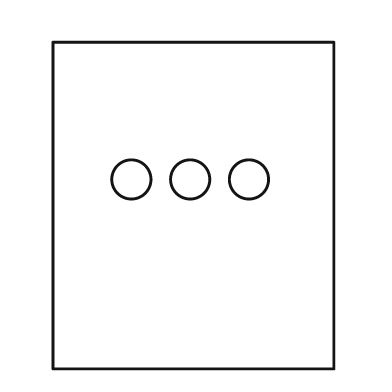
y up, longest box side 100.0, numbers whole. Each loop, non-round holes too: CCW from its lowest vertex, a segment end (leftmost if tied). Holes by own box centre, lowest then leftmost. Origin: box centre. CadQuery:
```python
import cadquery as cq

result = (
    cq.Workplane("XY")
    .moveTo(-43.0, -50.0)
    .lineTo(43.0, -50.0)
    .lineTo(43.0, 50.0)
    .lineTo(-43.0, 50.0)
    .close()
    .moveTo(-19.0, 8.0)
    .circle(6.0)
    .moveTo(-1.0, 8.0)
    .circle(6.0)
    .moveTo(17.0, 8.0)
    .circle(6.0)
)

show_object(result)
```